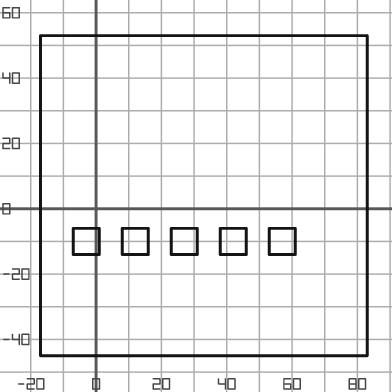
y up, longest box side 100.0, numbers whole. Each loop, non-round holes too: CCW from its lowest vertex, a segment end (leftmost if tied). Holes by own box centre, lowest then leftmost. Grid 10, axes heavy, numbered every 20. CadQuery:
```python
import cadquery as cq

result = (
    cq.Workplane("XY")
    .moveTo(-17.0, -45.0)
    .lineTo(83.0, -45.0)
    .lineTo(83.0, 53.0)
    .lineTo(-17.0, 53.0)
    .close()
    .moveTo(-7.0, -14.0)
    .lineTo(1.0, -14.0)
    .lineTo(1.0, -6.0)
    .lineTo(-7.0, -6.0)
    .close()
    .moveTo(8.0, -14.0)
    .lineTo(16.0, -14.0)
    .lineTo(16.0, -6.0)
    .lineTo(8.0, -6.0)
    .close()
    .moveTo(23.0, -14.0)
    .lineTo(31.0, -14.0)
    .lineTo(31.0, -6.0)
    .lineTo(23.0, -6.0)
    .close()
    .moveTo(38.0, -14.0)
    .lineTo(46.0, -14.0)
    .lineTo(46.0, -6.0)
    .lineTo(38.0, -6.0)
    .close()
    .moveTo(53.0, -14.0)
    .lineTo(61.0, -14.0)
    .lineTo(61.0, -6.0)
    .lineTo(53.0, -6.0)
    .close()
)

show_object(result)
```